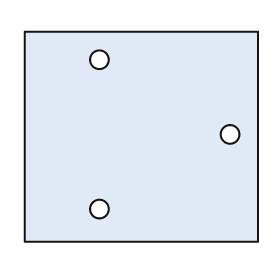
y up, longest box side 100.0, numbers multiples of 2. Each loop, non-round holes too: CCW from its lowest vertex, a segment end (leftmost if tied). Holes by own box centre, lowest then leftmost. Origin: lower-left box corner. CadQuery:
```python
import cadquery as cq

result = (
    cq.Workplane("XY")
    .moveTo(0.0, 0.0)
    .lineTo(100.0, 0.0)
    .lineTo(100.0, 90.0)
    .lineTo(0.0, 90.0)
    .close()
    .moveTo(32.0, 14.0)
    .circle(4.0)
    .moveTo(88.0, 46.0)
    .circle(4.0)
    .moveTo(32.0, 78.0)
    .circle(4.0)
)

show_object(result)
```